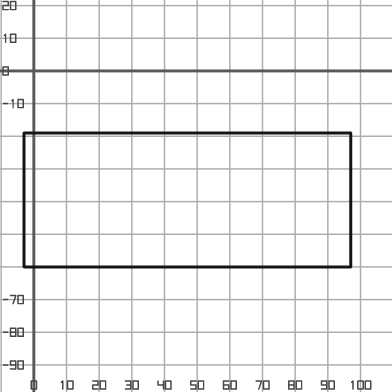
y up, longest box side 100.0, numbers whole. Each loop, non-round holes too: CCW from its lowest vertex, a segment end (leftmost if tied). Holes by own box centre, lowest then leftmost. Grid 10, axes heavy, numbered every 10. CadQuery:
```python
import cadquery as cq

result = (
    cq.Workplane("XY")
    .moveTo(-3.0, -60.0)
    .lineTo(97.0, -60.0)
    .lineTo(97.0, -19.0)
    .lineTo(-3.0, -19.0)
    .close()
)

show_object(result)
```